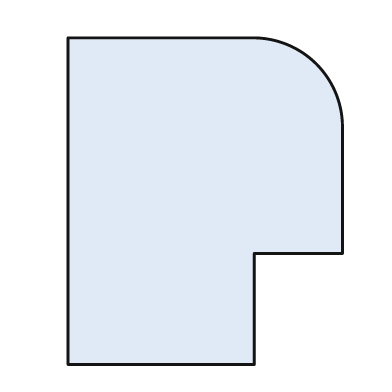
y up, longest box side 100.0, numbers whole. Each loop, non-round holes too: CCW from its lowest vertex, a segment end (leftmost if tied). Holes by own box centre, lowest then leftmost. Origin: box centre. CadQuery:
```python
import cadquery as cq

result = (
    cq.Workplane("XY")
    .moveTo(-42.0, -50.0)
    .lineTo(15.0, -50.0)
    .lineTo(15.0, -16.0)
    .lineTo(42.0, -16.0)
    .lineTo(42.0, 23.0)
    .threePointArc((34.0, 42.0), (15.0, 50.0))
    .lineTo(-42.0, 50.0)
    .close()
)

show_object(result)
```